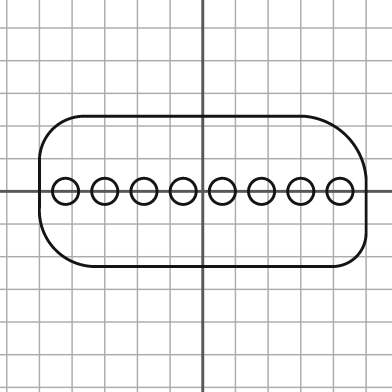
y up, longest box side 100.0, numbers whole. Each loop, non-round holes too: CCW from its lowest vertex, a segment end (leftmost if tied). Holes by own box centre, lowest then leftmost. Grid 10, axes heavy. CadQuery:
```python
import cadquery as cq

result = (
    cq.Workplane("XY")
    .moveTo(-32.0, -23.0)
    .lineTo(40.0, -23.0)
    .threePointArc((47.0, -20.0), (50.0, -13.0))
    .lineTo(50.0, 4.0)
    .threePointArc((44.0, 17.0), (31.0, 23.0))
    .lineTo(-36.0, 23.0)
    .threePointArc((-46.0, 19.0), (-50.0, 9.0))
    .lineTo(-50.0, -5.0)
    .threePointArc((-45.0, -18.0), (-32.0, -23.0))
    .close()
    .moveTo(-42.0, 0.0)
    .circle(4.0)
    .moveTo(-30.0, 0.0)
    .circle(4.0)
    .moveTo(-18.0, 0.0)
    .circle(4.0)
    .moveTo(-6.0, 0.0)
    .circle(4.0)
    .moveTo(6.0, 0.0)
    .circle(4.0)
    .moveTo(18.0, 0.0)
    .circle(4.0)
    .moveTo(30.0, 0.0)
    .circle(4.0)
    .moveTo(42.0, 0.0)
    .circle(4.0)
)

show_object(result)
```